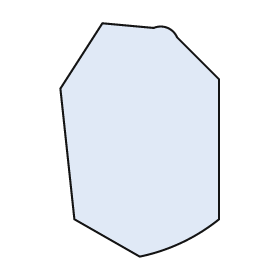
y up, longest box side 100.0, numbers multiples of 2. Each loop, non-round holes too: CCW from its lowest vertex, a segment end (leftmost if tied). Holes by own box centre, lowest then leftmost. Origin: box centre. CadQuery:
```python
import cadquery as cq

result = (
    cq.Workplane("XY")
    .moveTo(0.0, -50.0)
    .threePointArc((18.0, -44.0), (34.0, -34.0))
    .lineTo(34.0, 26.0)
    .lineTo(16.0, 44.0)
    .threePointArc((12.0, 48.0), (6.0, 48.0))
    .lineTo(-16.0, 50.0)
    .lineTo(-34.0, 22.0)
    .lineTo(-28.0, -34.0)
    .close()
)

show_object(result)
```